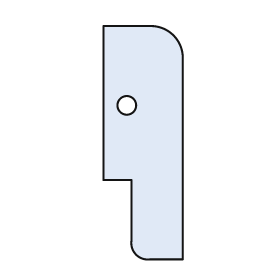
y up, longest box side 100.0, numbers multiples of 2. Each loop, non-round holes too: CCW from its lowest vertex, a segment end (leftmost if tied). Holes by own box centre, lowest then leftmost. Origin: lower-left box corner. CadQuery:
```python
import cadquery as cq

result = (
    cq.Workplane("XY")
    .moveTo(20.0, 0.0)
    .lineTo(34.0, 0.0)
    .lineTo(34.0, 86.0)
    .threePointArc((30.0, 96.0), (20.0, 100.0))
    .lineTo(0.0, 100.0)
    .lineTo(0.0, 34.0)
    .lineTo(12.0, 34.0)
    .lineTo(12.0, 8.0)
    .threePointArc((14.0, 2.0), (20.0, 0.0))
    .close()
    .moveTo(10.0, 66.0)
    .circle(4.0)
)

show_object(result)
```